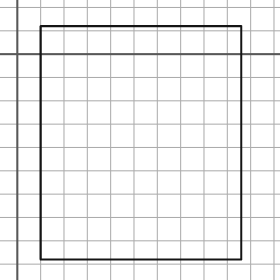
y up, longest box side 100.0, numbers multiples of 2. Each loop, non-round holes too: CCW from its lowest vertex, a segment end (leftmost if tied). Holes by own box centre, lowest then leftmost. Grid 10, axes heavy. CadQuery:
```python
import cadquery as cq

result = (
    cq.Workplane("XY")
    .moveTo(10.0, -88.0)
    .lineTo(96.0, -88.0)
    .lineTo(96.0, 12.0)
    .lineTo(10.0, 12.0)
    .close()
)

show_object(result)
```